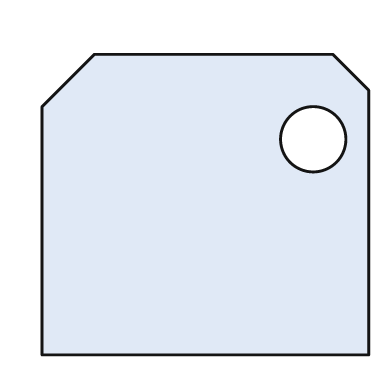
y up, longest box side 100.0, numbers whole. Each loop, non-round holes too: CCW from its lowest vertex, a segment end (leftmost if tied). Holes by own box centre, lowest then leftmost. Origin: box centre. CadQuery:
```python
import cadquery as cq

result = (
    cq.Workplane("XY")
    .moveTo(-50.0, -46.0)
    .lineTo(50.0, -46.0)
    .lineTo(50.0, 35.0)
    .lineTo(39.0, 46.0)
    .lineTo(-34.0, 46.0)
    .lineTo(-50.0, 30.0)
    .close()
    .moveTo(33.0, 20.0)
    .circle(10.0)
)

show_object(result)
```